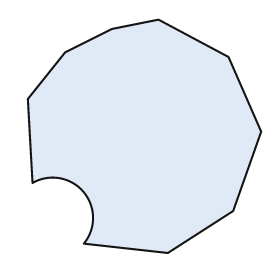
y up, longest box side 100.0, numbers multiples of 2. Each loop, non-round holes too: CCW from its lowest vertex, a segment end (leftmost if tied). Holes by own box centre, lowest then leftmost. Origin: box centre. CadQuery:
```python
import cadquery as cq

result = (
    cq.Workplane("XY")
    .moveTo(10.0, -50.0)
    .lineTo(38.0, -32.0)
    .lineTo(50.0, 2.0)
    .lineTo(36.0, 34.0)
    .lineTo(6.0, 50.0)
    .lineTo(-14.0, 46.0)
    .lineTo(-34.0, 36.0)
    .lineTo(-50.0, 16.0)
    .lineTo(-48.0, -20.0)
    .threePointArc((-26.0, -24.0), (-26.0, -46.0))
    .close()
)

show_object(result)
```